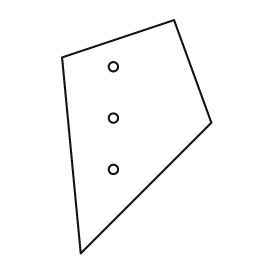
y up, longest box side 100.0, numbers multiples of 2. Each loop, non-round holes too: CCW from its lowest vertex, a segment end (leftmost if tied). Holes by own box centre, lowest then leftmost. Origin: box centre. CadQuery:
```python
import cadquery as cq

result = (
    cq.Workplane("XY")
    .moveTo(-24.0, -50.0)
    .lineTo(32.0, 6.0)
    .lineTo(16.0, 50.0)
    .lineTo(-32.0, 34.0)
    .close()
    .moveTo(-10.0, -14.0)
    .circle(2.0)
    .moveTo(-10.0, 8.0)
    .circle(2.0)
    .moveTo(-10.0, 30.0)
    .circle(2.0)
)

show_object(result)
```